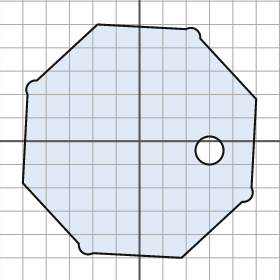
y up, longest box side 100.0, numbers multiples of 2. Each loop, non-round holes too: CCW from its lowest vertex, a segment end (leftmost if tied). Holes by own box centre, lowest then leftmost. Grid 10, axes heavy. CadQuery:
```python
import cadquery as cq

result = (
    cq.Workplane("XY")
    .moveTo(18.0, -50.0)
    .lineTo(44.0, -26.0)
    .threePointArc((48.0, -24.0), (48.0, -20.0))
    .lineTo(50.0, 18.0)
    .lineTo(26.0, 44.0)
    .threePointArc((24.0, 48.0), (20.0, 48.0))
    .lineTo(-18.0, 50.0)
    .lineTo(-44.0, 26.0)
    .threePointArc((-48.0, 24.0), (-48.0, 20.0))
    .lineTo(-50.0, -18.0)
    .lineTo(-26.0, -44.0)
    .threePointArc((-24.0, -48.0), (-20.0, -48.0))
    .close()
    .moveTo(30.0, -4.0)
    .circle(6.0)
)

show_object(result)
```